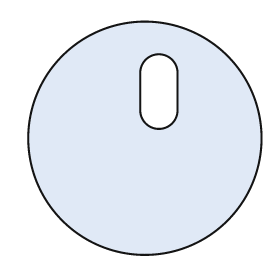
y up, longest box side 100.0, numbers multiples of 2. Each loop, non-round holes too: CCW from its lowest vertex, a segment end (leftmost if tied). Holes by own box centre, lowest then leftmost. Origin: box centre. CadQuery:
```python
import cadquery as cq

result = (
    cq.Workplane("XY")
    .moveTo(0.0, 0.0)
    .circle(50.0)
    .moveTo(-2.0, 12.0)
    .threePointArc((6.0, 4.0), (14.0, 12.0))
    .lineTo(14.0, 28.0)
    .threePointArc((6.0, 36.0), (-2.0, 28.0))
    .close()
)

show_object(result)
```